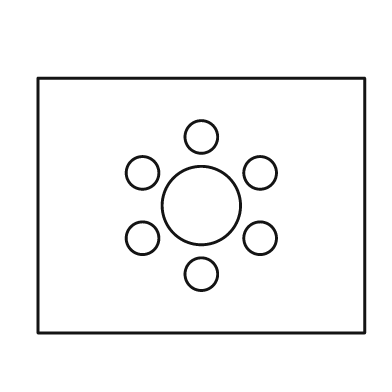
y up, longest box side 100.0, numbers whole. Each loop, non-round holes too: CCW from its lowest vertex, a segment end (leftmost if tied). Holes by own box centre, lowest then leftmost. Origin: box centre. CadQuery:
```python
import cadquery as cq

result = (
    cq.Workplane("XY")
    .moveTo(-50.0, -39.0)
    .lineTo(50.0, -39.0)
    .lineTo(50.0, 39.0)
    .lineTo(-50.0, 39.0)
    .close()
    .moveTo(0.0, -21.0)
    .circle(5.0)
    .moveTo(-18.0, -10.0)
    .circle(5.0)
    .moveTo(18.0, -10.0)
    .circle(5.0)
    .moveTo(0.0, 0.0)
    .circle(12.0)
    .moveTo(-18.0, 10.0)
    .circle(5.0)
    .moveTo(18.0, 10.0)
    .circle(5.0)
    .moveTo(0.0, 21.0)
    .circle(5.0)
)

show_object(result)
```